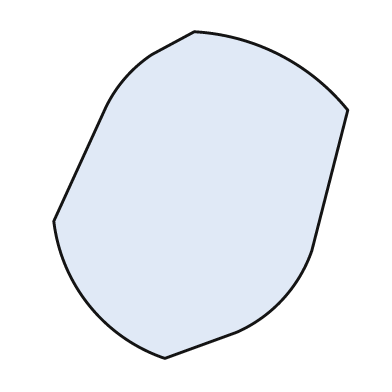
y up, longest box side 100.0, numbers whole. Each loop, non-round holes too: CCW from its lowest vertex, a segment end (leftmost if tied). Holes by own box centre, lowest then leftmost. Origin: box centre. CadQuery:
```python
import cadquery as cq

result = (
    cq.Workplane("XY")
    .moveTo(-11.0, -50.0)
    .lineTo(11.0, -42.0)
    .threePointArc((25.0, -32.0), (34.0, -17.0))
    .lineTo(45.0, 26.0)
    .threePointArc((24.0, 43.0), (-2.0, 50.0))
    .lineTo(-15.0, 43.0)
    .threePointArc((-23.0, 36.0), (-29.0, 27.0))
    .lineTo(-45.0, -8.0)
    .threePointArc((-34.0, -34.0), (-11.0, -50.0))
    .close()
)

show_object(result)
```